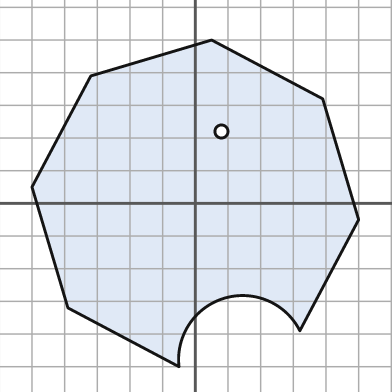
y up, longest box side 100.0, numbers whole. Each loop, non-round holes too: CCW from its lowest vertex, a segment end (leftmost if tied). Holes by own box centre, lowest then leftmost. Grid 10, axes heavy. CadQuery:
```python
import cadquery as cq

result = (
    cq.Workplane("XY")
    .moveTo(-5.0, -50.0)
    .threePointArc((9.0, -29.0), (32.0, -39.0))
    .lineTo(50.0, -5.0)
    .lineTo(39.0, 32.0)
    .lineTo(5.0, 50.0)
    .lineTo(-32.0, 39.0)
    .lineTo(-50.0, 5.0)
    .lineTo(-39.0, -32.0)
    .close()
    .moveTo(8.0, 22.0)
    .circle(2.0)
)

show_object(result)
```